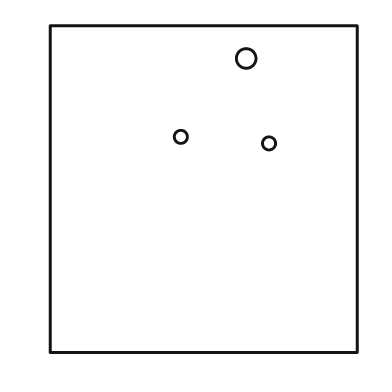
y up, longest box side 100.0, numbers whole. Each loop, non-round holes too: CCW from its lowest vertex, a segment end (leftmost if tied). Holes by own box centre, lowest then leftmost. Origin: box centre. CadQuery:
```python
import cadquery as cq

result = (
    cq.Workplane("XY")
    .moveTo(-47.0, -50.0)
    .lineTo(47.0, -50.0)
    .lineTo(47.0, 50.0)
    .lineTo(-47.0, 50.0)
    .close()
    .moveTo(20.0, 14.0)
    .circle(2.0)
    .moveTo(-7.0, 16.0)
    .circle(2.0)
    .moveTo(13.0, 40.0)
    .circle(3.0)
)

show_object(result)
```